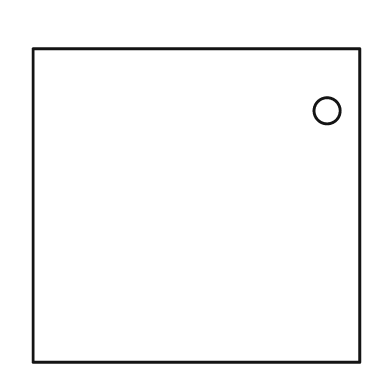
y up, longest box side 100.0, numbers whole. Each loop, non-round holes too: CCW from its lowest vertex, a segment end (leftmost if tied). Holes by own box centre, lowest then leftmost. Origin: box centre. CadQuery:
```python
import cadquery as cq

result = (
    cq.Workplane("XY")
    .moveTo(-50.0, -48.0)
    .lineTo(50.0, -48.0)
    .lineTo(50.0, 48.0)
    .lineTo(-50.0, 48.0)
    .close()
    .moveTo(40.0, 29.0)
    .circle(4.0)
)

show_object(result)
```